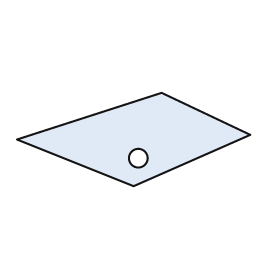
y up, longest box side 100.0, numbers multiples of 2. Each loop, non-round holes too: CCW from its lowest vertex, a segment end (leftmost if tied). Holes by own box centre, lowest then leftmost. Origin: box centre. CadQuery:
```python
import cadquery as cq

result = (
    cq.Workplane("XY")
    .moveTo(0.0, -20.0)
    .lineTo(50.0, 2.0)
    .lineTo(12.0, 20.0)
    .lineTo(-50.0, 0.0)
    .close()
    .moveTo(2.0, -8.0)
    .circle(4.0)
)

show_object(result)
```